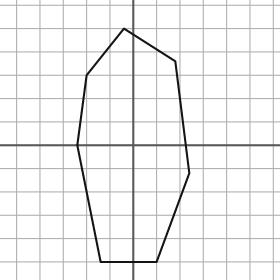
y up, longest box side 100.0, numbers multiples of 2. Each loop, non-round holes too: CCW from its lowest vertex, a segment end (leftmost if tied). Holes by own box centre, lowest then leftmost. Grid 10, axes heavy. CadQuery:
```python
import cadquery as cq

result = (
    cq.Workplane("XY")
    .moveTo(-14.0, -50.0)
    .lineTo(10.0, -50.0)
    .lineTo(24.0, -12.0)
    .lineTo(18.0, 36.0)
    .lineTo(-4.0, 50.0)
    .lineTo(-20.0, 30.0)
    .lineTo(-24.0, 0.0)
    .close()
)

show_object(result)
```